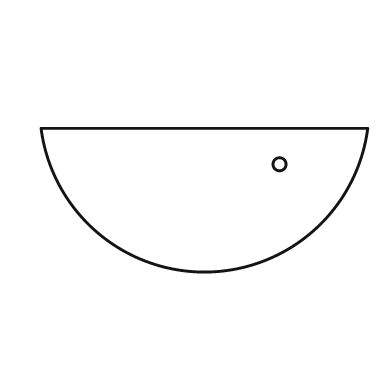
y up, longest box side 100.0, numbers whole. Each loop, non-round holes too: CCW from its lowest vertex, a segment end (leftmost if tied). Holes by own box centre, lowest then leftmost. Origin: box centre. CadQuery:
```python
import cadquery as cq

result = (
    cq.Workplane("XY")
    .moveTo(-50.0, 22.0)
    .threePointArc((0.0, -22.0), (50.0, 22.0))
    .close()
    .moveTo(23.0, 11.0)
    .circle(2.0)
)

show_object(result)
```